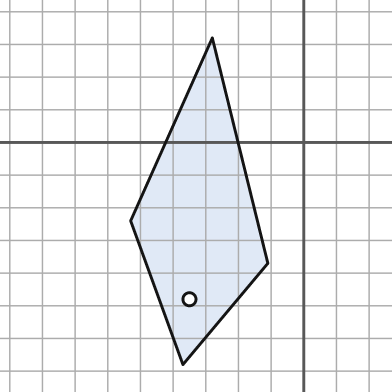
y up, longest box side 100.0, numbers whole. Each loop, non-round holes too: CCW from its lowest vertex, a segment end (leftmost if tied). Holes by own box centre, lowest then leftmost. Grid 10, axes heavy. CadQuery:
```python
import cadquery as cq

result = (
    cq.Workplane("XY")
    .moveTo(-37.0, -68.0)
    .lineTo(-11.0, -37.0)
    .lineTo(-28.0, 32.0)
    .lineTo(-53.0, -24.0)
    .close()
    .moveTo(-35.0, -48.0)
    .circle(2.0)
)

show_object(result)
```